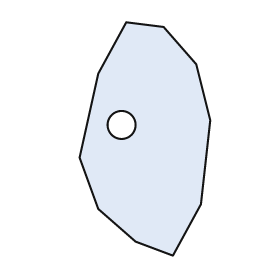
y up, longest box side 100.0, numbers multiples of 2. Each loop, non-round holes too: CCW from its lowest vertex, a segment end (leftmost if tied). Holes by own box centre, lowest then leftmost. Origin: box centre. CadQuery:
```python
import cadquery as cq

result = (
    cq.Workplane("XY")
    .moveTo(12.0, -50.0)
    .lineTo(24.0, -28.0)
    .lineTo(28.0, 8.0)
    .lineTo(22.0, 32.0)
    .lineTo(8.0, 48.0)
    .lineTo(-8.0, 50.0)
    .lineTo(-20.0, 28.0)
    .lineTo(-28.0, -8.0)
    .lineTo(-20.0, -30.0)
    .lineTo(-4.0, -44.0)
    .close()
    .moveTo(-10.0, 6.0)
    .circle(6.0)
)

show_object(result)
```